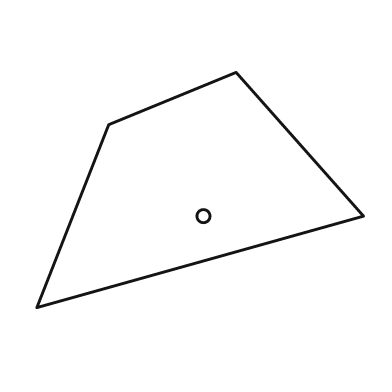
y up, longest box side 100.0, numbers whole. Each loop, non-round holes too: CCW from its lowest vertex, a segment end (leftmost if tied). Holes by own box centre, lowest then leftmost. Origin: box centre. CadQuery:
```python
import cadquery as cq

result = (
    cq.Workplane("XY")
    .moveTo(-50.0, -36.0)
    .lineTo(50.0, -8.0)
    .lineTo(11.0, 36.0)
    .lineTo(-28.0, 20.0)
    .close()
    .moveTo(1.0, -8.0)
    .circle(2.0)
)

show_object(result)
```